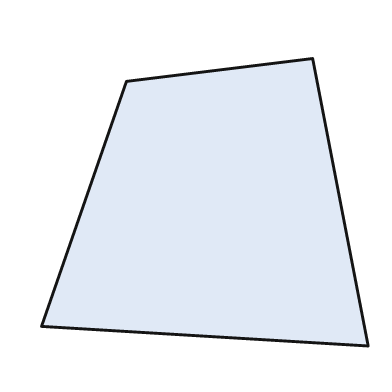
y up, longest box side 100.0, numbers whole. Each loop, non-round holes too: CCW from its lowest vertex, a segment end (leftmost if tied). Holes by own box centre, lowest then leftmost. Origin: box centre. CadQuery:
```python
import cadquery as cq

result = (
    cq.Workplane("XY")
    .moveTo(50.0, -44.0)
    .lineTo(33.0, 44.0)
    .lineTo(-24.0, 37.0)
    .lineTo(-50.0, -38.0)
    .close()
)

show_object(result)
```